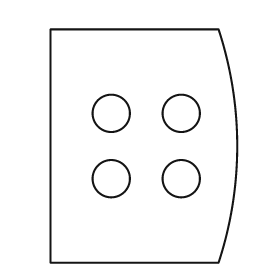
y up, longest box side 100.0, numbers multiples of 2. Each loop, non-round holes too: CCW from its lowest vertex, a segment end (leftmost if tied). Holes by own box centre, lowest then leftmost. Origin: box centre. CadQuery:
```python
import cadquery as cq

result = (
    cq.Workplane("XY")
    .moveTo(-40.0, -50.0)
    .lineTo(32.0, -50.0)
    .threePointArc((40.0, 0.0), (32.0, 50.0))
    .lineTo(-40.0, 50.0)
    .close()
    .moveTo(-14.0, -14.0)
    .circle(8.0)
    .moveTo(16.0, -14.0)
    .circle(8.0)
    .moveTo(-14.0, 14.0)
    .circle(8.0)
    .moveTo(16.0, 14.0)
    .circle(8.0)
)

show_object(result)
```